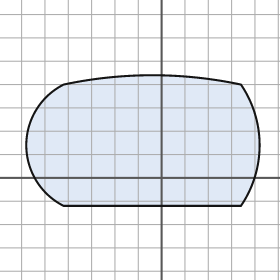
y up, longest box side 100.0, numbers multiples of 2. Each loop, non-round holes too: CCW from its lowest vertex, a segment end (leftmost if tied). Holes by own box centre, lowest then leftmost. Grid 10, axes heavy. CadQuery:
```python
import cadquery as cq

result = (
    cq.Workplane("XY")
    .moveTo(-42.0, -12.0)
    .lineTo(34.0, -12.0)
    .threePointArc((42.0, 14.0), (34.0, 40.0))
    .threePointArc((-4.0, 44.0), (-42.0, 40.0))
    .threePointArc((-58.0, 14.0), (-42.0, -12.0))
    .close()
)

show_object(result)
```